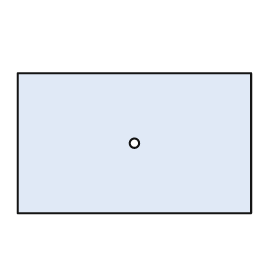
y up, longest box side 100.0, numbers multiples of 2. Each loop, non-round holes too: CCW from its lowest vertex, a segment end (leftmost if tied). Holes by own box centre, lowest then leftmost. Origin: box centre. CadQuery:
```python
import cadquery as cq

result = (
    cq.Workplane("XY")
    .moveTo(-50.0, -30.0)
    .lineTo(50.0, -30.0)
    .lineTo(50.0, 30.0)
    .lineTo(-50.0, 30.0)
    .close()
    .moveTo(0.0, 0.0)
    .circle(2.0)
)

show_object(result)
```